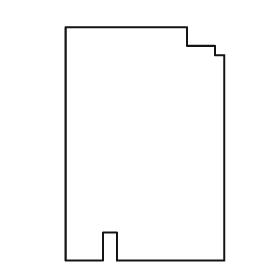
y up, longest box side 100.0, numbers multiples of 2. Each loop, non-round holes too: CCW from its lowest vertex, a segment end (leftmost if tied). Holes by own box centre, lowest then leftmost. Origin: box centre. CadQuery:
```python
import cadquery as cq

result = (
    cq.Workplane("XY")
    .moveTo(-34.0, -50.0)
    .lineTo(-18.0, -50.0)
    .lineTo(-18.0, -38.0)
    .lineTo(-12.0, -38.0)
    .lineTo(-12.0, -50.0)
    .lineTo(34.0, -50.0)
    .lineTo(34.0, 38.0)
    .lineTo(30.0, 38.0)
    .lineTo(30.0, 42.0)
    .lineTo(18.0, 42.0)
    .lineTo(18.0, 50.0)
    .lineTo(-34.0, 50.0)
    .close()
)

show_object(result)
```